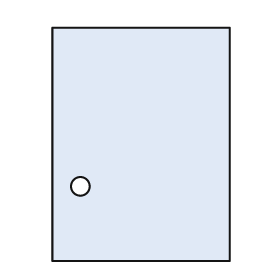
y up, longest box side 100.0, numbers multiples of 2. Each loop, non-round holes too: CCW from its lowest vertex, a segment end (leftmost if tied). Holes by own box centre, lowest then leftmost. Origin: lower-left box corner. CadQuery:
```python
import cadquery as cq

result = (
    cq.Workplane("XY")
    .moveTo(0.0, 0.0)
    .lineTo(76.0, 0.0)
    .lineTo(76.0, 100.0)
    .lineTo(0.0, 100.0)
    .close()
    .moveTo(12.0, 32.0)
    .circle(4.0)
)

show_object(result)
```